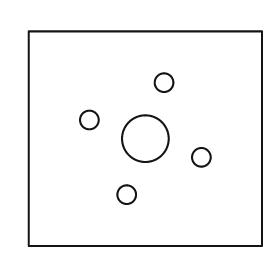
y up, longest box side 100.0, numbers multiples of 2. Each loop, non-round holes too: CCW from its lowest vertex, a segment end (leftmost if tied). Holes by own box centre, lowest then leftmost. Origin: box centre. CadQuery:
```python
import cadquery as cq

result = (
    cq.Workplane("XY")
    .moveTo(-50.0, -46.0)
    .lineTo(50.0, -46.0)
    .lineTo(50.0, 46.0)
    .lineTo(-50.0, 46.0)
    .close()
    .moveTo(-8.0, -24.0)
    .circle(4.0)
    .moveTo(24.0, -8.0)
    .circle(4.0)
    .moveTo(0.0, 0.0)
    .circle(10.0)
    .moveTo(-24.0, 8.0)
    .circle(4.0)
    .moveTo(8.0, 24.0)
    .circle(4.0)
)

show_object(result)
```